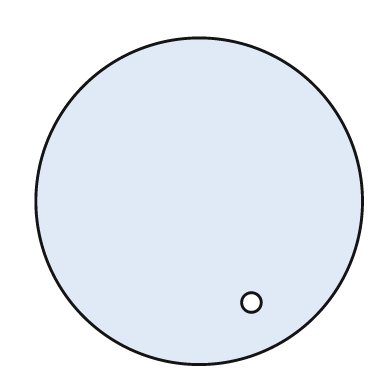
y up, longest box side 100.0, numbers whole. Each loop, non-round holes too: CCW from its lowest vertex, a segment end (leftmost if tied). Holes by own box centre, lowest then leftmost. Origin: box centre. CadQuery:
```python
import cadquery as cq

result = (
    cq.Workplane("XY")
    .moveTo(0.0, 0.0)
    .circle(50.0)
    .moveTo(16.0, -31.0)
    .circle(3.0)
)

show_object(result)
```